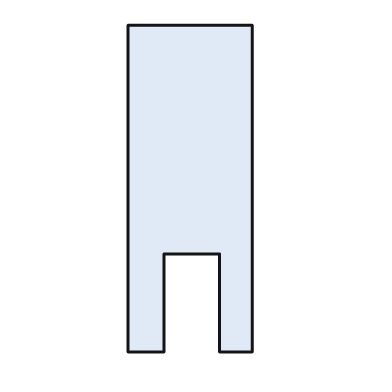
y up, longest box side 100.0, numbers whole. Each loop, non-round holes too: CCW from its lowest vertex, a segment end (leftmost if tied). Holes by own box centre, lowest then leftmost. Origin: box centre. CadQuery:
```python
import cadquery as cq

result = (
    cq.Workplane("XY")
    .moveTo(-19.0, -50.0)
    .lineTo(-8.0, -50.0)
    .lineTo(-8.0, -20.0)
    .lineTo(9.0, -20.0)
    .lineTo(9.0, -50.0)
    .lineTo(19.0, -50.0)
    .lineTo(19.0, 50.0)
    .lineTo(-19.0, 50.0)
    .close()
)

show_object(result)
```